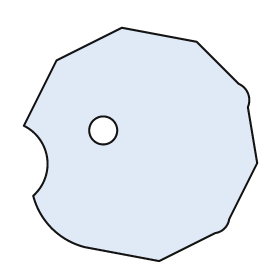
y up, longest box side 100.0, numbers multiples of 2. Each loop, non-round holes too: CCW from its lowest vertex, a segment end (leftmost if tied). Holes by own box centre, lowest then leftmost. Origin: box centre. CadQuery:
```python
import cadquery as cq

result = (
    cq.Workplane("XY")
    .moveTo(8.0, -50.0)
    .lineTo(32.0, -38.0)
    .threePointArc((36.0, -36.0), (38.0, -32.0))
    .lineTo(50.0, -8.0)
    .lineTo(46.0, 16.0)
    .threePointArc((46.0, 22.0), (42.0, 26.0))
    .lineTo(24.0, 44.0)
    .lineTo(-8.0, 50.0)
    .lineTo(-36.0, 36.0)
    .lineTo(-50.0, 8.0)
    .threePointArc((-40.0, -6.0), (-46.0, -22.0))
    .threePointArc((-38.0, -36.0), (-24.0, -44.0))
    .close()
    .moveTo(-16.0, 6.0)
    .circle(6.0)
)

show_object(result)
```